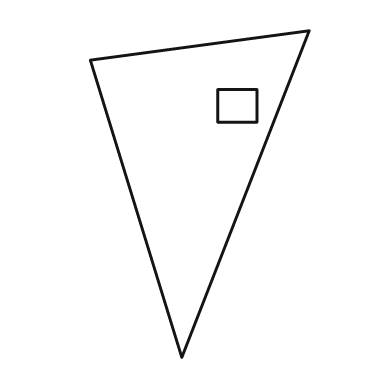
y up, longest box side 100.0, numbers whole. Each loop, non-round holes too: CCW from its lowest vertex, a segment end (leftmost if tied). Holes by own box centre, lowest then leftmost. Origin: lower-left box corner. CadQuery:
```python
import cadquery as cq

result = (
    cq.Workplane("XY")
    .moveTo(28.0, 0.0)
    .lineTo(67.0, 100.0)
    .lineTo(0.0, 91.0)
    .close()
    .moveTo(39.0, 72.0)
    .lineTo(51.0, 72.0)
    .lineTo(51.0, 82.0)
    .lineTo(39.0, 82.0)
    .close()
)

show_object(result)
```